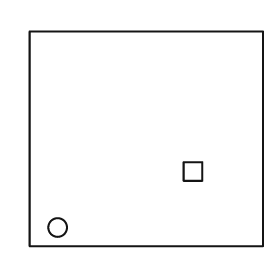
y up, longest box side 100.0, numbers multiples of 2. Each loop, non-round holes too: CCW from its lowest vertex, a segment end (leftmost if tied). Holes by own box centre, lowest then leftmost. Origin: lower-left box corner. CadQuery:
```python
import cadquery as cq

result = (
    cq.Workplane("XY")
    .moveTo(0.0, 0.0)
    .lineTo(100.0, 0.0)
    .lineTo(100.0, 92.0)
    .lineTo(0.0, 92.0)
    .close()
    .moveTo(12.0, 8.0)
    .circle(4.0)
    .moveTo(66.0, 28.0)
    .lineTo(74.0, 28.0)
    .lineTo(74.0, 36.0)
    .lineTo(66.0, 36.0)
    .close()
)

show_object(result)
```